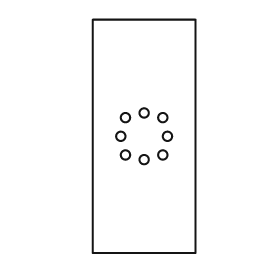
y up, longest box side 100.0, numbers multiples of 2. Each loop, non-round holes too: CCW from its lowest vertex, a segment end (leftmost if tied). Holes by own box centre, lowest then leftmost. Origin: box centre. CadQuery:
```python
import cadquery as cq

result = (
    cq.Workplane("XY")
    .moveTo(-22.0, -50.0)
    .lineTo(22.0, -50.0)
    .lineTo(22.0, 50.0)
    .lineTo(-22.0, 50.0)
    .close()
    .moveTo(0.0, -10.0)
    .circle(2.0)
    .moveTo(-8.0, -8.0)
    .circle(2.0)
    .moveTo(8.0, -8.0)
    .circle(2.0)
    .moveTo(-10.0, 0.0)
    .circle(2.0)
    .moveTo(10.0, 0.0)
    .circle(2.0)
    .moveTo(-8.0, 8.0)
    .circle(2.0)
    .moveTo(8.0, 8.0)
    .circle(2.0)
    .moveTo(0.0, 10.0)
    .circle(2.0)
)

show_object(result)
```